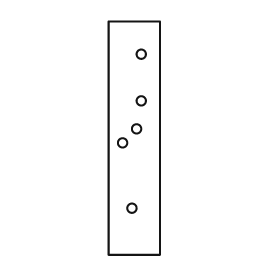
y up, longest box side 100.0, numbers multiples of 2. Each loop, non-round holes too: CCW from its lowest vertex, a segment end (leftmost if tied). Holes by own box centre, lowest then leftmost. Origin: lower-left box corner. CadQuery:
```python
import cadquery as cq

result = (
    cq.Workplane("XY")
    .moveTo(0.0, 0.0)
    .lineTo(22.0, 0.0)
    .lineTo(22.0, 100.0)
    .lineTo(0.0, 100.0)
    .close()
    .moveTo(10.0, 20.0)
    .circle(2.0)
    .moveTo(6.0, 48.0)
    .circle(2.0)
    .moveTo(12.0, 54.0)
    .circle(2.0)
    .moveTo(14.0, 66.0)
    .circle(2.0)
    .moveTo(14.0, 86.0)
    .circle(2.0)
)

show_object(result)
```